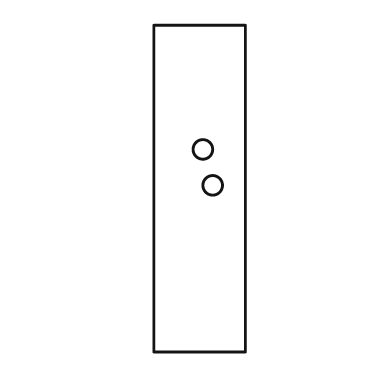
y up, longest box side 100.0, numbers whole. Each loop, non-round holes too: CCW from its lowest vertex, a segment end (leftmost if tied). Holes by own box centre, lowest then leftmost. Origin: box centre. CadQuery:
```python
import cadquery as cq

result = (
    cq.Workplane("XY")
    .moveTo(-14.0, -50.0)
    .lineTo(14.0, -50.0)
    .lineTo(14.0, 50.0)
    .lineTo(-14.0, 50.0)
    .close()
    .moveTo(4.0, 1.0)
    .circle(3.0)
    .moveTo(1.0, 12.0)
    .circle(3.0)
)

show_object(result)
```